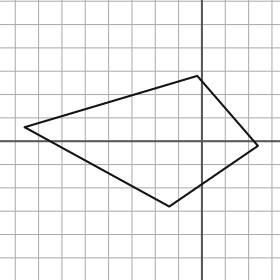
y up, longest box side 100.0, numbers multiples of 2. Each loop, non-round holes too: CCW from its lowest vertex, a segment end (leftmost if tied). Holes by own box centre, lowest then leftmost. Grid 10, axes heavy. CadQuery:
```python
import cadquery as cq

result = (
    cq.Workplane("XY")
    .moveTo(-14.0, -28.0)
    .lineTo(24.0, -2.0)
    .lineTo(-2.0, 28.0)
    .lineTo(-76.0, 6.0)
    .close()
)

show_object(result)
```